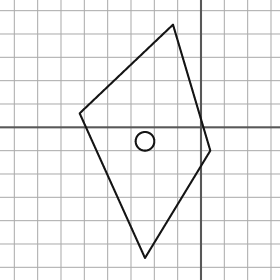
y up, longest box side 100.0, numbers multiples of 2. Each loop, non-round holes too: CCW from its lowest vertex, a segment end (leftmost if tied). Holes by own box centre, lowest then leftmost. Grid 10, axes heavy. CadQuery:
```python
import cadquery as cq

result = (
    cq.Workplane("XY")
    .moveTo(-24.0, -56.0)
    .lineTo(4.0, -10.0)
    .lineTo(-12.0, 44.0)
    .lineTo(-52.0, 6.0)
    .close()
    .moveTo(-24.0, -6.0)
    .circle(4.0)
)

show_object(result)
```